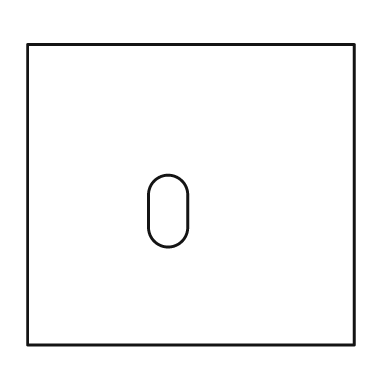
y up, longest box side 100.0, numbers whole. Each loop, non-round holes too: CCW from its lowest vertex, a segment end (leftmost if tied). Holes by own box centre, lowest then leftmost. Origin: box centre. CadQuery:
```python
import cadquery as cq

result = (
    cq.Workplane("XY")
    .moveTo(-50.0, -46.0)
    .lineTo(50.0, -46.0)
    .lineTo(50.0, 46.0)
    .lineTo(-50.0, 46.0)
    .close()
    .moveTo(-13.0, -10.0)
    .threePointArc((-7.0, -16.0), (-1.0, -10.0))
    .lineTo(-1.0, 0.0)
    .threePointArc((-7.0, 6.0), (-13.0, 0.0))
    .close()
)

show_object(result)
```